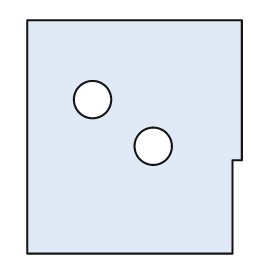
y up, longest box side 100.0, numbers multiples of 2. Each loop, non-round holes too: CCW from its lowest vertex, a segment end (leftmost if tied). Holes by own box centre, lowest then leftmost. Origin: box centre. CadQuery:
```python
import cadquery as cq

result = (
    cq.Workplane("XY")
    .moveTo(-46.0, -50.0)
    .lineTo(42.0, -50.0)
    .lineTo(42.0, -10.0)
    .lineTo(46.0, -10.0)
    .lineTo(46.0, 50.0)
    .lineTo(-46.0, 50.0)
    .close()
    .moveTo(8.0, -4.0)
    .circle(8.0)
    .moveTo(-18.0, 16.0)
    .circle(8.0)
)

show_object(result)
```